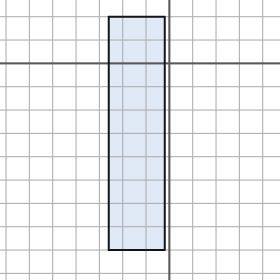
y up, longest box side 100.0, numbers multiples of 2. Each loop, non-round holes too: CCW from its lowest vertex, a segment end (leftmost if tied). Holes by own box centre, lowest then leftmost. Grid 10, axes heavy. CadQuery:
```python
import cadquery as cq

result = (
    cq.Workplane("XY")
    .moveTo(-26.0, -80.0)
    .lineTo(-2.0, -80.0)
    .lineTo(-2.0, 20.0)
    .lineTo(-26.0, 20.0)
    .close()
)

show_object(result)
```